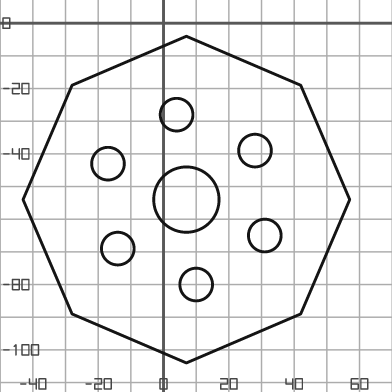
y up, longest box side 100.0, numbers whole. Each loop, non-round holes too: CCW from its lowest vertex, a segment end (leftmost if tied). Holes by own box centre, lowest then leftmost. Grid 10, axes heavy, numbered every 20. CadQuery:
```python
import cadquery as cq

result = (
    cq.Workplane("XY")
    .moveTo(7.0, -104.0)
    .lineTo(42.0, -89.0)
    .lineTo(57.0, -54.0)
    .lineTo(42.0, -19.0)
    .lineTo(7.0, -4.0)
    .lineTo(-28.0, -19.0)
    .lineTo(-43.0, -54.0)
    .lineTo(-28.0, -89.0)
    .close()
    .moveTo(10.0, -80.0)
    .circle(5.0)
    .moveTo(-14.0, -69.0)
    .circle(5.0)
    .moveTo(31.0, -65.0)
    .circle(5.0)
    .moveTo(7.0, -54.0)
    .circle(10.0)
    .moveTo(-17.0, -43.0)
    .circle(5.0)
    .moveTo(28.0, -39.0)
    .circle(5.0)
    .moveTo(4.0, -28.0)
    .circle(5.0)
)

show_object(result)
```